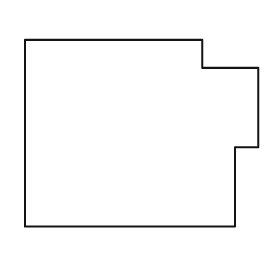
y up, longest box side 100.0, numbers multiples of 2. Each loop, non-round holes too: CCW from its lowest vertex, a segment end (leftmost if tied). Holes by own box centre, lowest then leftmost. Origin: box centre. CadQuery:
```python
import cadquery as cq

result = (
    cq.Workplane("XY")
    .moveTo(-50.0, -40.0)
    .lineTo(40.0, -40.0)
    .lineTo(40.0, -6.0)
    .lineTo(50.0, -6.0)
    .lineTo(50.0, 28.0)
    .lineTo(26.0, 28.0)
    .lineTo(26.0, 40.0)
    .lineTo(-50.0, 40.0)
    .close()
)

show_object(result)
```